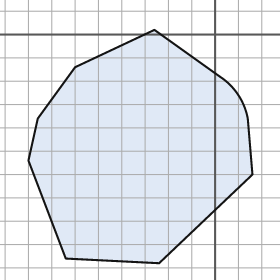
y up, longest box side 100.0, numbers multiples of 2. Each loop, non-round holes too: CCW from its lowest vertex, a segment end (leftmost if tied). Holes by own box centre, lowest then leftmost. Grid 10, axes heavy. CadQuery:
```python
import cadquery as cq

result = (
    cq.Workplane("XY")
    .moveTo(-24.0, -98.0)
    .lineTo(16.0, -60.0)
    .lineTo(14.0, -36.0)
    .threePointArc((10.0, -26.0), (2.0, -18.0))
    .lineTo(-26.0, 2.0)
    .lineTo(-60.0, -14.0)
    .lineTo(-76.0, -36.0)
    .lineTo(-80.0, -54.0)
    .lineTo(-64.0, -96.0)
    .close()
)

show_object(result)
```